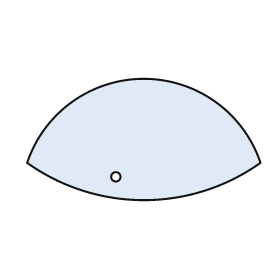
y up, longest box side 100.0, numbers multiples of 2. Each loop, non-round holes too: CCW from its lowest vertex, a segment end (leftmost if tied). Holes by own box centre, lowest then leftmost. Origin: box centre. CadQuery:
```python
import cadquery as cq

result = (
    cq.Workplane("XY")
    .moveTo(-50.0, -10.0)
    .threePointArc((0.0, -26.0), (50.0, -10.0))
    .threePointArc((0.0, 26.0), (-50.0, -10.0))
    .close()
    .moveTo(-12.0, -16.0)
    .circle(2.0)
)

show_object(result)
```